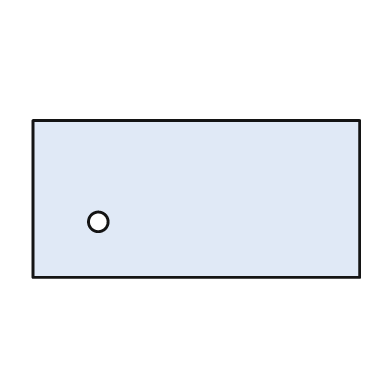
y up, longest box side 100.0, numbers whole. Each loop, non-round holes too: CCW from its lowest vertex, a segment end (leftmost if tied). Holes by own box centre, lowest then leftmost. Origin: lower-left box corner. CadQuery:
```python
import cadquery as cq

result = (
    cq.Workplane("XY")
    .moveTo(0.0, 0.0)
    .lineTo(100.0, 0.0)
    .lineTo(100.0, 48.0)
    .lineTo(0.0, 48.0)
    .close()
    .moveTo(20.0, 17.0)
    .circle(3.0)
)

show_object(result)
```